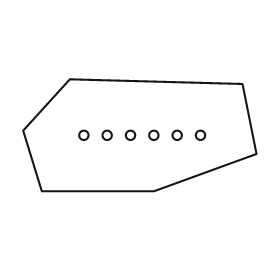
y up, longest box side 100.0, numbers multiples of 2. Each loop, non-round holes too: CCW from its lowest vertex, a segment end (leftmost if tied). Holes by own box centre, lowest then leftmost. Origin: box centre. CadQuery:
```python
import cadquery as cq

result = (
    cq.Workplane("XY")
    .moveTo(-42.0, -24.0)
    .lineTo(6.0, -24.0)
    .lineTo(50.0, -8.0)
    .lineTo(44.0, 22.0)
    .lineTo(-30.0, 24.0)
    .lineTo(-50.0, 2.0)
    .close()
    .moveTo(-24.0, 0.0)
    .circle(2.0)
    .moveTo(-14.0, 0.0)
    .circle(2.0)
    .moveTo(-4.0, 0.0)
    .circle(2.0)
    .moveTo(6.0, 0.0)
    .circle(2.0)
    .moveTo(16.0, 0.0)
    .circle(2.0)
    .moveTo(26.0, 0.0)
    .circle(2.0)
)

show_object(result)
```